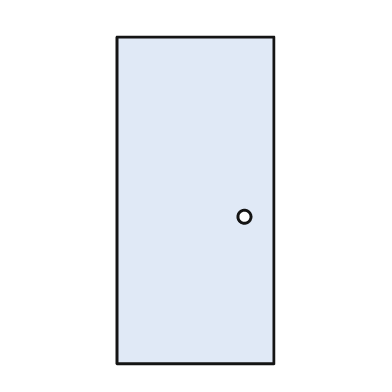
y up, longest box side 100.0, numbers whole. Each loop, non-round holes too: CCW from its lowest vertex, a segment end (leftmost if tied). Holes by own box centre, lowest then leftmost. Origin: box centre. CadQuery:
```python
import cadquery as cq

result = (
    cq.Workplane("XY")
    .moveTo(-24.0, -50.0)
    .lineTo(24.0, -50.0)
    .lineTo(24.0, 50.0)
    .lineTo(-24.0, 50.0)
    .close()
    .moveTo(15.0, -5.0)
    .circle(2.0)
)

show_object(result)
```